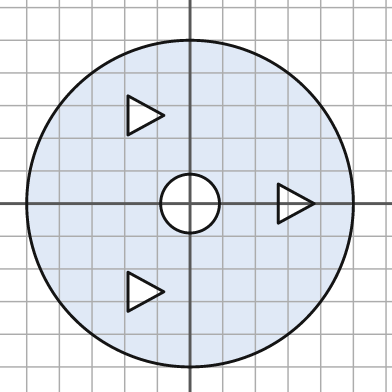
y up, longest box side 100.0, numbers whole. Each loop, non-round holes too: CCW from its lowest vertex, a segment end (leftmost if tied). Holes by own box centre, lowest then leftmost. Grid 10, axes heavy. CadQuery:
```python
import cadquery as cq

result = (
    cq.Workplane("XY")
    .moveTo(0.0, 0.0)
    .circle(50.0)
    .moveTo(-19.0, -33.0)
    .lineTo(-8.0, -27.0)
    .lineTo(-19.0, -21.0)
    .close()
    .moveTo(0.0, 0.0)
    .circle(9.0)
    .moveTo(27.0, -6.0)
    .lineTo(38.0, 0.0)
    .lineTo(27.0, 6.0)
    .close()
    .moveTo(-19.0, 21.0)
    .lineTo(-8.0, 27.0)
    .lineTo(-19.0, 33.0)
    .close()
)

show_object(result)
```